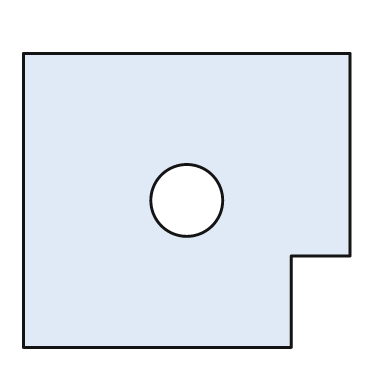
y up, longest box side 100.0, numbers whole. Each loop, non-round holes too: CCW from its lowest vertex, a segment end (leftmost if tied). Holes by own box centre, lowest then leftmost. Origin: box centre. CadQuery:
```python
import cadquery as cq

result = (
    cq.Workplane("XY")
    .moveTo(-50.0, -45.0)
    .lineTo(32.0, -45.0)
    .lineTo(32.0, -17.0)
    .lineTo(50.0, -17.0)
    .lineTo(50.0, 45.0)
    .lineTo(-50.0, 45.0)
    .close()
    .moveTo(0.0, 0.0)
    .circle(11.0)
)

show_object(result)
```